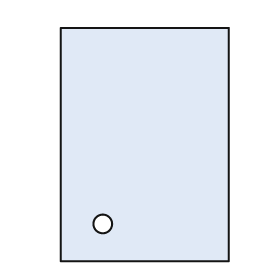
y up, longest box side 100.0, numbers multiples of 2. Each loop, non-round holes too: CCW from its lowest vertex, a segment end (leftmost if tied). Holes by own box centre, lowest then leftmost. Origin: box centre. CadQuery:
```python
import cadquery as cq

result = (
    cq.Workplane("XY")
    .moveTo(-36.0, -50.0)
    .lineTo(36.0, -50.0)
    .lineTo(36.0, 50.0)
    .lineTo(-36.0, 50.0)
    .close()
    .moveTo(-18.0, -34.0)
    .circle(4.0)
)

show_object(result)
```